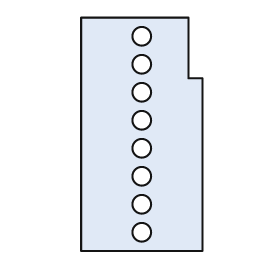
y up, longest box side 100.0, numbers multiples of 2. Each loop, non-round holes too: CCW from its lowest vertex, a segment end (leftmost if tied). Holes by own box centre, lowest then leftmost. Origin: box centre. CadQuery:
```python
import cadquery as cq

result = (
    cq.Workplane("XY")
    .moveTo(-26.0, -50.0)
    .lineTo(26.0, -50.0)
    .lineTo(26.0, 24.0)
    .lineTo(20.0, 24.0)
    .lineTo(20.0, 50.0)
    .lineTo(-26.0, 50.0)
    .close()
    .moveTo(0.0, -42.0)
    .circle(4.0)
    .moveTo(0.0, -30.0)
    .circle(4.0)
    .moveTo(0.0, -18.0)
    .circle(4.0)
    .moveTo(0.0, -6.0)
    .circle(4.0)
    .moveTo(0.0, 6.0)
    .circle(4.0)
    .moveTo(0.0, 18.0)
    .circle(4.0)
    .moveTo(0.0, 30.0)
    .circle(4.0)
    .moveTo(0.0, 42.0)
    .circle(4.0)
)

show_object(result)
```